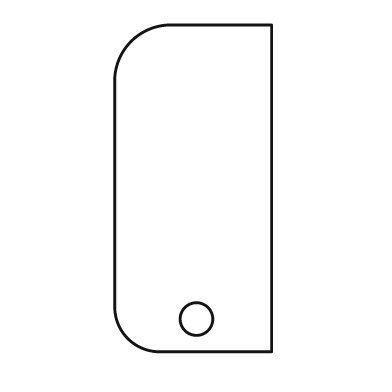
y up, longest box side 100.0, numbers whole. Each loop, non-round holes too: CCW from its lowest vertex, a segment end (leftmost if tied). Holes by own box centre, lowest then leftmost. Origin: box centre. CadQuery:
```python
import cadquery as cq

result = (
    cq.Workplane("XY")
    .moveTo(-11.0, -50.0)
    .lineTo(24.0, -50.0)
    .lineTo(24.0, 50.0)
    .lineTo(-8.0, 50.0)
    .threePointArc((-19.0, 45.0), (-24.0, 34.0))
    .lineTo(-24.0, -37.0)
    .threePointArc((-20.0, -46.0), (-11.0, -50.0))
    .close()
    .moveTo(1.0, -40.0)
    .circle(5.0)
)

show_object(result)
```